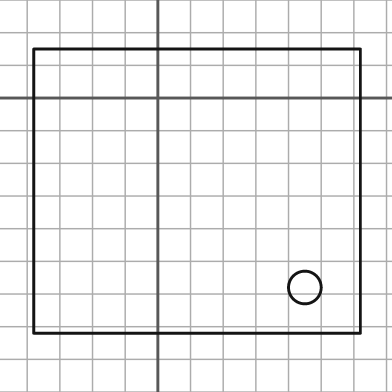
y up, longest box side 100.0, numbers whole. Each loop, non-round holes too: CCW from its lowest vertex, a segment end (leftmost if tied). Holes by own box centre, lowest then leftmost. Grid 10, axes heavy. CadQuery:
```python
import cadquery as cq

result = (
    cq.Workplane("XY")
    .moveTo(-38.0, -72.0)
    .lineTo(62.0, -72.0)
    .lineTo(62.0, 15.0)
    .lineTo(-38.0, 15.0)
    .close()
    .moveTo(45.0, -58.0)
    .circle(5.0)
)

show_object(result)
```